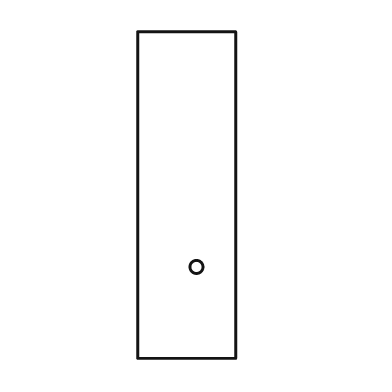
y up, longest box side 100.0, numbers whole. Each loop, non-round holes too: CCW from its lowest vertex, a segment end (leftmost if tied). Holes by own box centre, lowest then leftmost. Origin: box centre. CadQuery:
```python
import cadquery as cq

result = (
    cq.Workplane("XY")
    .moveTo(-15.0, -50.0)
    .lineTo(15.0, -50.0)
    .lineTo(15.0, 50.0)
    .lineTo(-15.0, 50.0)
    .close()
    .moveTo(3.0, -22.0)
    .circle(2.0)
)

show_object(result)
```